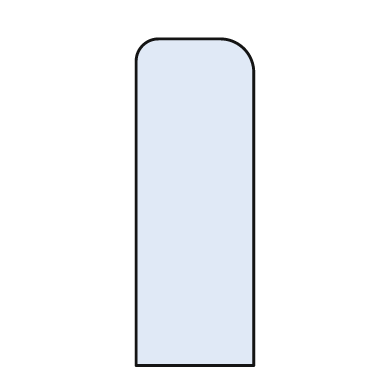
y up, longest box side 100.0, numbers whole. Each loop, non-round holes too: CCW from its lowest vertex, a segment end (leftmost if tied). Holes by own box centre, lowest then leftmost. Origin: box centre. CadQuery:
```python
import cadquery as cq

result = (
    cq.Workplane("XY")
    .moveTo(-18.0, -50.0)
    .lineTo(18.0, -50.0)
    .lineTo(18.0, 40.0)
    .threePointArc((15.0, 47.0), (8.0, 50.0))
    .lineTo(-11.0, 50.0)
    .threePointArc((-16.0, 48.0), (-18.0, 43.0))
    .close()
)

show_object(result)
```